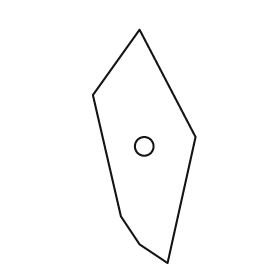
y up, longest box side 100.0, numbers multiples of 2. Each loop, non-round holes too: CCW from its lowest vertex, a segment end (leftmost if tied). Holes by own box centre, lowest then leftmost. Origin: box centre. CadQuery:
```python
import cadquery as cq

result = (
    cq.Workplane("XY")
    .moveTo(10.0, -50.0)
    .lineTo(22.0, 4.0)
    .lineTo(-2.0, 50.0)
    .lineTo(-22.0, 22.0)
    .lineTo(-10.0, -30.0)
    .lineTo(-2.0, -42.0)
    .close()
    .moveTo(0.0, 0.0)
    .circle(4.0)
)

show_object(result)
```